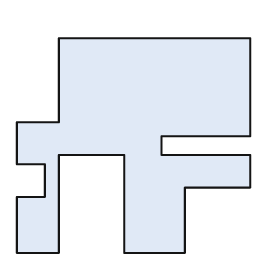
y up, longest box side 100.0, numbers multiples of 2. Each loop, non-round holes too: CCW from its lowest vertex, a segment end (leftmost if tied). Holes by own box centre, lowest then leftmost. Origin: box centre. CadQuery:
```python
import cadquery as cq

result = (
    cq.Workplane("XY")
    .moveTo(-50.0, -46.0)
    .lineTo(-32.0, -46.0)
    .lineTo(-32.0, -4.0)
    .lineTo(-4.0, -4.0)
    .lineTo(-4.0, -46.0)
    .lineTo(22.0, -46.0)
    .lineTo(22.0, -18.0)
    .lineTo(50.0, -18.0)
    .lineTo(50.0, -4.0)
    .lineTo(12.0, -4.0)
    .lineTo(12.0, 4.0)
    .lineTo(50.0, 4.0)
    .lineTo(50.0, 46.0)
    .lineTo(-32.0, 46.0)
    .lineTo(-32.0, 10.0)
    .lineTo(-50.0, 10.0)
    .lineTo(-50.0, -8.0)
    .lineTo(-38.0, -8.0)
    .lineTo(-38.0, -22.0)
    .lineTo(-50.0, -22.0)
    .close()
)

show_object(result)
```